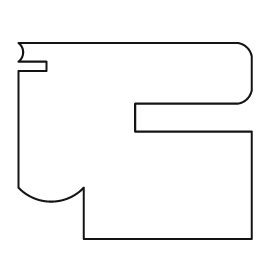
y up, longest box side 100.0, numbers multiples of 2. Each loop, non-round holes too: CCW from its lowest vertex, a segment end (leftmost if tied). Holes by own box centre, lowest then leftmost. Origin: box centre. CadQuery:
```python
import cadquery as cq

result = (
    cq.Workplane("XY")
    .moveTo(-22.0, -42.0)
    .lineTo(50.0, -42.0)
    .lineTo(50.0, 4.0)
    .lineTo(0.0, 4.0)
    .lineTo(0.0, 16.0)
    .lineTo(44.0, 16.0)
    .threePointArc((48.0, 18.0), (50.0, 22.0))
    .lineTo(50.0, 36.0)
    .threePointArc((48.0, 40.0), (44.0, 42.0))
    .lineTo(-50.0, 42.0)
    .threePointArc((-48.0, 38.0), (-50.0, 34.0))
    .lineTo(-38.0, 34.0)
    .lineTo(-38.0, 30.0)
    .lineTo(-50.0, 30.0)
    .lineTo(-50.0, -20.0)
    .threePointArc((-36.0, -26.0), (-22.0, -20.0))
    .close()
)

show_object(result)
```